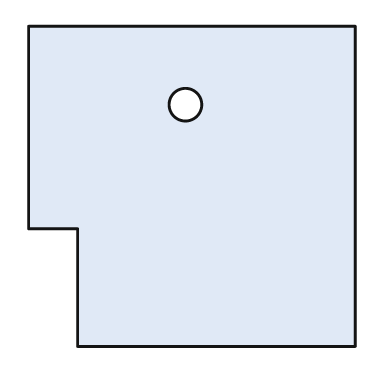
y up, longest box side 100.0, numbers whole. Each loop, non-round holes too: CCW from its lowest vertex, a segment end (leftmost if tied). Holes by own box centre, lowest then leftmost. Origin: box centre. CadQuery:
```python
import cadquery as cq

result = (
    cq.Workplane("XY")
    .moveTo(-35.0, -49.0)
    .lineTo(50.0, -49.0)
    .lineTo(50.0, 49.0)
    .lineTo(-50.0, 49.0)
    .lineTo(-50.0, -13.0)
    .lineTo(-35.0, -13.0)
    .close()
    .moveTo(-2.0, 25.0)
    .circle(5.0)
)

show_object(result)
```